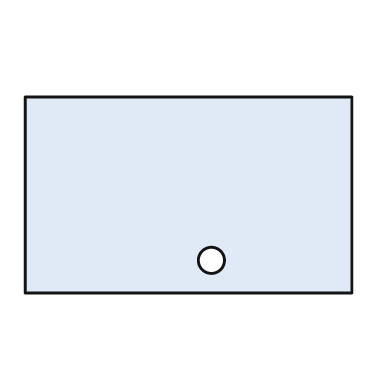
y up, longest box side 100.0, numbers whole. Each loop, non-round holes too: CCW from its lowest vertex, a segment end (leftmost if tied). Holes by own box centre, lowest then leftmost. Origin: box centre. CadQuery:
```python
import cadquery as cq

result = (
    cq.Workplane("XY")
    .moveTo(-50.0, -30.0)
    .lineTo(50.0, -30.0)
    .lineTo(50.0, 30.0)
    .lineTo(-50.0, 30.0)
    .close()
    .moveTo(7.0, -20.0)
    .circle(4.0)
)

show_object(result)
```